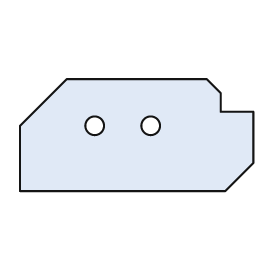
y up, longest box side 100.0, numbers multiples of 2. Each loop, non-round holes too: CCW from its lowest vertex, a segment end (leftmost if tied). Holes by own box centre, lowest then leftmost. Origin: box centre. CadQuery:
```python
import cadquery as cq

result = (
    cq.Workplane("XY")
    .moveTo(-50.0, -24.0)
    .lineTo(38.0, -24.0)
    .lineTo(50.0, -12.0)
    .lineTo(50.0, 10.0)
    .lineTo(36.0, 10.0)
    .lineTo(36.0, 18.0)
    .lineTo(30.0, 24.0)
    .lineTo(-30.0, 24.0)
    .lineTo(-50.0, 4.0)
    .close()
    .moveTo(-18.0, 4.0)
    .circle(4.0)
    .moveTo(6.0, 4.0)
    .circle(4.0)
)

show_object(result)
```